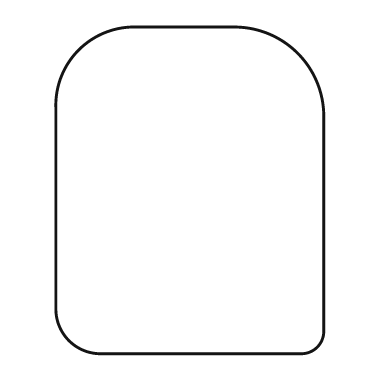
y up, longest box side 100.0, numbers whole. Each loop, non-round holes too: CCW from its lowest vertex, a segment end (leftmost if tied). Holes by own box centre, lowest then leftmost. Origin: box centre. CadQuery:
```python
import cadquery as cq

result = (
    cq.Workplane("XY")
    .moveTo(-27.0, -50.0)
    .lineTo(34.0, -50.0)
    .threePointArc((39.0, -48.0), (41.0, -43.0))
    .lineTo(41.0, 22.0)
    .threePointArc((33.0, 42.0), (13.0, 50.0))
    .lineTo(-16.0, 50.0)
    .threePointArc((-34.0, 43.0), (-41.0, 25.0))
    .lineTo(-41.0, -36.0)
    .threePointArc((-37.0, -46.0), (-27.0, -50.0))
    .close()
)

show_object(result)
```